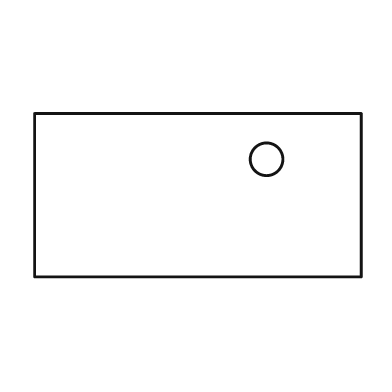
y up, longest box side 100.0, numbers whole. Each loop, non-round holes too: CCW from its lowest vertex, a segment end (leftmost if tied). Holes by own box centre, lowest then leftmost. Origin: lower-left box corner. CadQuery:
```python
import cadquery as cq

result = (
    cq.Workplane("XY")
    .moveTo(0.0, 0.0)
    .lineTo(100.0, 0.0)
    .lineTo(100.0, 50.0)
    .lineTo(0.0, 50.0)
    .close()
    .moveTo(71.0, 36.0)
    .circle(5.0)
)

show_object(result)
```